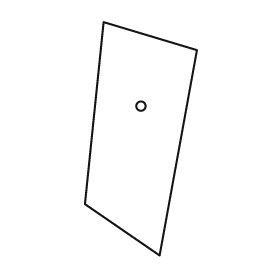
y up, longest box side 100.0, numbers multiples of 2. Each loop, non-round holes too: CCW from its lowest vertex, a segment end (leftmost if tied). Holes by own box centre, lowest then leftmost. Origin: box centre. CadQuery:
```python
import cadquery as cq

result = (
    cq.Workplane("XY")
    .moveTo(8.0, -50.0)
    .lineTo(24.0, 38.0)
    .lineTo(-16.0, 50.0)
    .lineTo(-24.0, -28.0)
    .close()
    .moveTo(0.0, 14.0)
    .circle(2.0)
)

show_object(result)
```